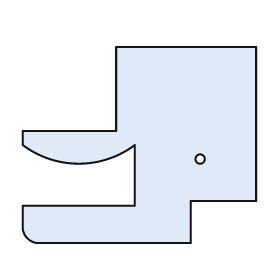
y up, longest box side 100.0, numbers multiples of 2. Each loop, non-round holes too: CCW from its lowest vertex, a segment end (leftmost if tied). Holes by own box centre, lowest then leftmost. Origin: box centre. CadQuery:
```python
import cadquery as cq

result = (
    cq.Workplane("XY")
    .moveTo(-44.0, -42.0)
    .lineTo(22.0, -42.0)
    .lineTo(22.0, -24.0)
    .lineTo(50.0, -24.0)
    .lineTo(50.0, 42.0)
    .lineTo(-10.0, 42.0)
    .lineTo(-10.0, 6.0)
    .lineTo(-50.0, 6.0)
    .lineTo(-50.0, 0.0)
    .threePointArc((-26.0, -8.0), (-2.0, 0.0))
    .lineTo(-2.0, -26.0)
    .lineTo(-50.0, -26.0)
    .lineTo(-50.0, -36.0)
    .threePointArc((-48.0, -40.0), (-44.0, -42.0))
    .close()
    .moveTo(26.0, -6.0)
    .circle(2.0)
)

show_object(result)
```